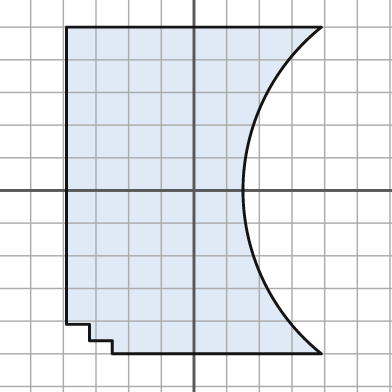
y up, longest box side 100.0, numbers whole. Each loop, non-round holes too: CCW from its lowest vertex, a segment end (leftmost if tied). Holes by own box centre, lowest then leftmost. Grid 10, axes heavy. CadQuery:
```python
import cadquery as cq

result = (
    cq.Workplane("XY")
    .moveTo(-25.0, -50.0)
    .lineTo(39.0, -50.0)
    .threePointArc((15.0, 0.0), (39.0, 50.0))
    .lineTo(-39.0, 50.0)
    .lineTo(-39.0, -41.0)
    .lineTo(-32.0, -41.0)
    .lineTo(-32.0, -46.0)
    .lineTo(-25.0, -46.0)
    .close()
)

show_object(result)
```